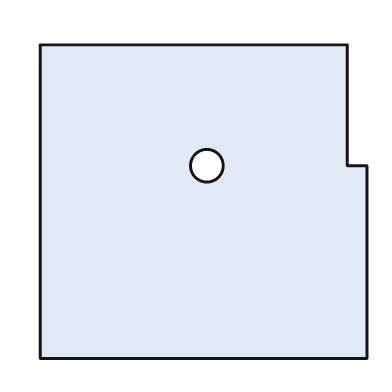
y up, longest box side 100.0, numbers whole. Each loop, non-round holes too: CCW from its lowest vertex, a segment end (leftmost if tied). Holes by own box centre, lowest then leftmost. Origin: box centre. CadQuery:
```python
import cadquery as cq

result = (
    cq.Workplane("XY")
    .moveTo(-50.0, -48.0)
    .lineTo(50.0, -48.0)
    .lineTo(50.0, 11.0)
    .lineTo(44.0, 11.0)
    .lineTo(44.0, 48.0)
    .lineTo(-50.0, 48.0)
    .close()
    .moveTo(1.0, 11.0)
    .circle(5.0)
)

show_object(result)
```